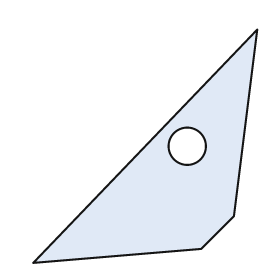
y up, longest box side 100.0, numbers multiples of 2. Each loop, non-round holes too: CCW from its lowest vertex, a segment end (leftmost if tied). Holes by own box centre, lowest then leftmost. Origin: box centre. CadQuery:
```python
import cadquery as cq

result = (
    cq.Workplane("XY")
    .moveTo(-48.0, -50.0)
    .lineTo(24.0, -44.0)
    .lineTo(38.0, -30.0)
    .lineTo(48.0, 50.0)
    .close()
    .moveTo(18.0, 0.0)
    .circle(8.0)
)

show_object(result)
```